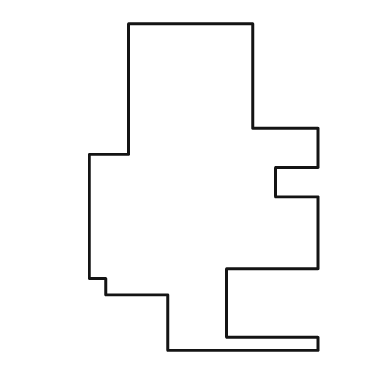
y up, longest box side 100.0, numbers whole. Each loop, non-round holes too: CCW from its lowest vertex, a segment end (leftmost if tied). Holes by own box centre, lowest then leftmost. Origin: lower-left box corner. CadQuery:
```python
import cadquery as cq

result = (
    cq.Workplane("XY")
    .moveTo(24.0, 0.0)
    .lineTo(70.0, 0.0)
    .lineTo(70.0, 4.0)
    .lineTo(42.0, 4.0)
    .lineTo(42.0, 25.0)
    .lineTo(70.0, 25.0)
    .lineTo(70.0, 47.0)
    .lineTo(57.0, 47.0)
    .lineTo(57.0, 56.0)
    .lineTo(70.0, 56.0)
    .lineTo(70.0, 68.0)
    .lineTo(50.0, 68.0)
    .lineTo(50.0, 100.0)
    .lineTo(12.0, 100.0)
    .lineTo(12.0, 60.0)
    .lineTo(0.0, 60.0)
    .lineTo(0.0, 22.0)
    .lineTo(5.0, 22.0)
    .lineTo(5.0, 17.0)
    .lineTo(24.0, 17.0)
    .close()
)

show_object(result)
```